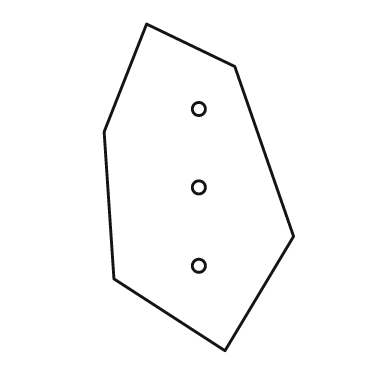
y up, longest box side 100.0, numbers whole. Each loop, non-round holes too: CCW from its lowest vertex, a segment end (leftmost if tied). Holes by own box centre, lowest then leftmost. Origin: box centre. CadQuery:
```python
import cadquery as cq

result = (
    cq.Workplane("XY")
    .moveTo(8.0, -50.0)
    .lineTo(29.0, -15.0)
    .lineTo(11.0, 37.0)
    .lineTo(-16.0, 50.0)
    .lineTo(-29.0, 17.0)
    .lineTo(-26.0, -28.0)
    .close()
    .moveTo(0.0, -24.0)
    .circle(2.0)
    .moveTo(0.0, 0.0)
    .circle(2.0)
    .moveTo(0.0, 24.0)
    .circle(2.0)
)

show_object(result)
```